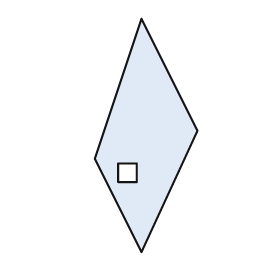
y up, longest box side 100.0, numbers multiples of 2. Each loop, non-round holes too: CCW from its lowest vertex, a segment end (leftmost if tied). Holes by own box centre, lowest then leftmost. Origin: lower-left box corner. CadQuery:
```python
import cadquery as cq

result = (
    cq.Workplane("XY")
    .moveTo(20.0, 0.0)
    .lineTo(44.0, 52.0)
    .lineTo(20.0, 100.0)
    .lineTo(0.0, 40.0)
    .close()
    .moveTo(10.0, 30.0)
    .lineTo(18.0, 30.0)
    .lineTo(18.0, 38.0)
    .lineTo(10.0, 38.0)
    .close()
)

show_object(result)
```